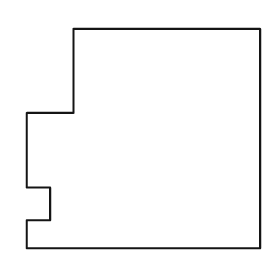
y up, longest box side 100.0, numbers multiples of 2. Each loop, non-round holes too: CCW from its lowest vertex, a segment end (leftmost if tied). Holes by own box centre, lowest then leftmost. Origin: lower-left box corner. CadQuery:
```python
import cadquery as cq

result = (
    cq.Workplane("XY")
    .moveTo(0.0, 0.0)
    .lineTo(100.0, 0.0)
    .lineTo(100.0, 94.0)
    .lineTo(20.0, 94.0)
    .lineTo(20.0, 58.0)
    .lineTo(0.0, 58.0)
    .lineTo(0.0, 26.0)
    .lineTo(10.0, 26.0)
    .lineTo(10.0, 12.0)
    .lineTo(0.0, 12.0)
    .close()
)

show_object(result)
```